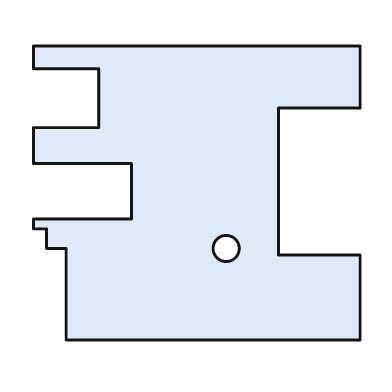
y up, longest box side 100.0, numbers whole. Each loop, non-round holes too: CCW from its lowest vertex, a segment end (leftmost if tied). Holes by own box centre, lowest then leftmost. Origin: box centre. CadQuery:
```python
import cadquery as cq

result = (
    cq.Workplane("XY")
    .moveTo(-40.0, -45.0)
    .lineTo(50.0, -45.0)
    .lineTo(50.0, -19.0)
    .lineTo(25.0, -19.0)
    .lineTo(25.0, 26.0)
    .lineTo(50.0, 26.0)
    .lineTo(50.0, 45.0)
    .lineTo(-50.0, 45.0)
    .lineTo(-50.0, 38.0)
    .lineTo(-30.0, 38.0)
    .lineTo(-30.0, 20.0)
    .lineTo(-50.0, 20.0)
    .lineTo(-50.0, 9.0)
    .lineTo(-20.0, 9.0)
    .lineTo(-20.0, -8.0)
    .lineTo(-50.0, -8.0)
    .lineTo(-50.0, -11.0)
    .lineTo(-46.0, -11.0)
    .lineTo(-46.0, -17.0)
    .lineTo(-40.0, -17.0)
    .close()
    .moveTo(9.0, -17.0)
    .circle(4.0)
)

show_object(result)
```